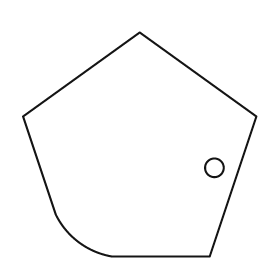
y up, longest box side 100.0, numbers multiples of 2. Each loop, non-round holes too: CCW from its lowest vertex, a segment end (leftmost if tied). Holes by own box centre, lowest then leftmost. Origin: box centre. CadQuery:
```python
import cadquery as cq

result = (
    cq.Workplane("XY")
    .moveTo(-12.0, -48.0)
    .lineTo(30.0, -48.0)
    .lineTo(50.0, 12.0)
    .lineTo(0.0, 48.0)
    .lineTo(-50.0, 12.0)
    .lineTo(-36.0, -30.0)
    .threePointArc((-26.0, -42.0), (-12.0, -48.0))
    .close()
    .moveTo(32.0, -10.0)
    .circle(4.0)
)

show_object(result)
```